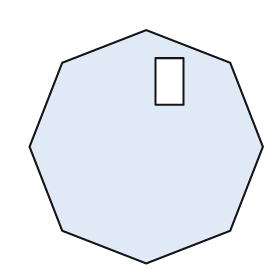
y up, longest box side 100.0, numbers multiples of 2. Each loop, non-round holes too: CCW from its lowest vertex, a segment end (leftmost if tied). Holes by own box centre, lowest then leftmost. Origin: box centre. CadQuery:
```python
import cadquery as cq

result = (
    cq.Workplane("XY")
    .moveTo(0.0, -50.0)
    .lineTo(36.0, -36.0)
    .lineTo(50.0, 0.0)
    .lineTo(36.0, 36.0)
    .lineTo(0.0, 50.0)
    .lineTo(-36.0, 36.0)
    .lineTo(-50.0, 0.0)
    .lineTo(-36.0, -36.0)
    .close()
    .moveTo(4.0, 18.0)
    .lineTo(16.0, 18.0)
    .lineTo(16.0, 38.0)
    .lineTo(4.0, 38.0)
    .close()
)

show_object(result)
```